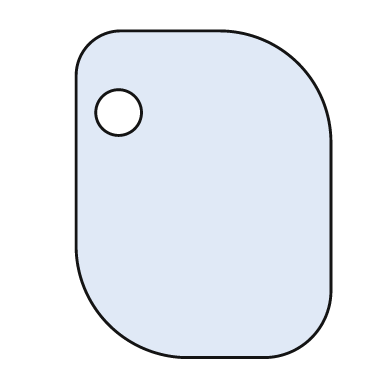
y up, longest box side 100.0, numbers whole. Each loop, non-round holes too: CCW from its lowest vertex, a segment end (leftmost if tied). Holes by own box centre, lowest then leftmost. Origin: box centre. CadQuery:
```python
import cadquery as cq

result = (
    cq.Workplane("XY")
    .moveTo(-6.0, -50.0)
    .lineTo(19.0, -50.0)
    .threePointArc((33.0, -44.0), (39.0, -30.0))
    .lineTo(39.0, 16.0)
    .threePointArc((29.0, 40.0), (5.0, 50.0))
    .lineTo(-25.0, 50.0)
    .threePointArc((-35.0, 46.0), (-39.0, 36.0))
    .lineTo(-39.0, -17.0)
    .threePointArc((-29.0, -40.0), (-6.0, -50.0))
    .close()
    .moveTo(-26.0, 25.0)
    .circle(7.0)
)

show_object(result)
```